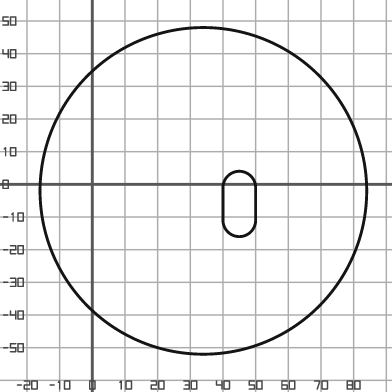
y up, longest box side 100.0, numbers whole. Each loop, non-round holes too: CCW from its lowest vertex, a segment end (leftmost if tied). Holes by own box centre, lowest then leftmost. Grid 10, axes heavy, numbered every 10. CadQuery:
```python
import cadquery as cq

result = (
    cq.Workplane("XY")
    .moveTo(34.0, -2.0)
    .circle(50.0)
    .moveTo(40.0, -11.0)
    .threePointArc((45.0, -16.0), (50.0, -11.0))
    .lineTo(50.0, -1.0)
    .threePointArc((45.0, 4.0), (40.0, -1.0))
    .close()
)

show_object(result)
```